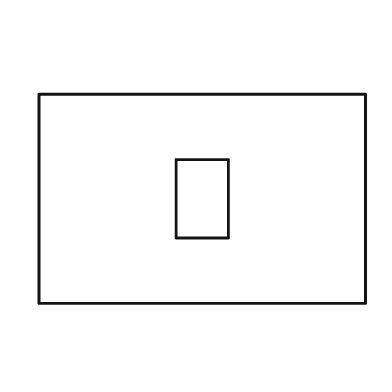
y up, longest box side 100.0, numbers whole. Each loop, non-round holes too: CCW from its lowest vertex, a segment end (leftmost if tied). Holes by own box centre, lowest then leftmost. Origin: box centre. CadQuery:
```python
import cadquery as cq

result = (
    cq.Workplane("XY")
    .moveTo(-50.0, -32.0)
    .lineTo(50.0, -32.0)
    .lineTo(50.0, 32.0)
    .lineTo(-50.0, 32.0)
    .close()
    .moveTo(-8.0, -12.0)
    .lineTo(8.0, -12.0)
    .lineTo(8.0, 12.0)
    .lineTo(-8.0, 12.0)
    .close()
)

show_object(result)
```